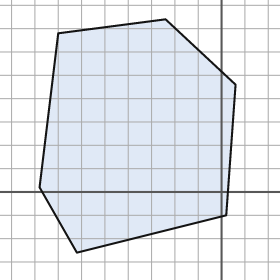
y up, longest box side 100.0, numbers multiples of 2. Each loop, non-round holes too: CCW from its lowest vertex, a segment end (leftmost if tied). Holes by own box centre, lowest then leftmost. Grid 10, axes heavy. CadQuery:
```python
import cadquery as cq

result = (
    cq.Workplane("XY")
    .moveTo(-62.0, -26.0)
    .lineTo(2.0, -10.0)
    .lineTo(6.0, 46.0)
    .lineTo(-24.0, 74.0)
    .lineTo(-70.0, 68.0)
    .lineTo(-78.0, 2.0)
    .close()
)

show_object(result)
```